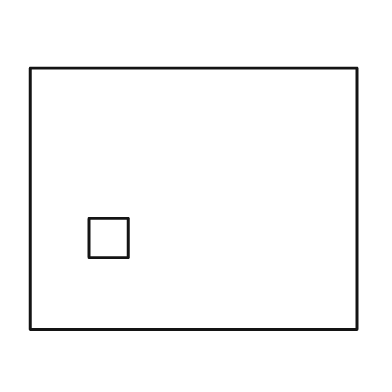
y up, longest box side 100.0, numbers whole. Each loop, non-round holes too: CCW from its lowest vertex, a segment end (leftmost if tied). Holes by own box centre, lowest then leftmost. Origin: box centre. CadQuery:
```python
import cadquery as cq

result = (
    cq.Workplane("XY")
    .moveTo(-50.0, -40.0)
    .lineTo(50.0, -40.0)
    .lineTo(50.0, 40.0)
    .lineTo(-50.0, 40.0)
    .close()
    .moveTo(-32.0, -18.0)
    .lineTo(-20.0, -18.0)
    .lineTo(-20.0, -6.0)
    .lineTo(-32.0, -6.0)
    .close()
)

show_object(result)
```